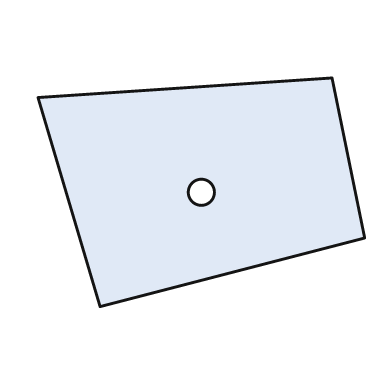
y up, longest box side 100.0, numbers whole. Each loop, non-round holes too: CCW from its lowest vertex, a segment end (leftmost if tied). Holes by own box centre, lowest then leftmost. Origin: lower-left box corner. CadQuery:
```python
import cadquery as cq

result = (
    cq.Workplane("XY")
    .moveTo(19.0, 0.0)
    .lineTo(100.0, 21.0)
    .lineTo(90.0, 70.0)
    .lineTo(0.0, 64.0)
    .close()
    .moveTo(50.0, 35.0)
    .circle(4.0)
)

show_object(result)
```